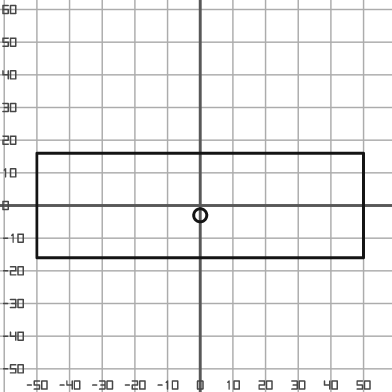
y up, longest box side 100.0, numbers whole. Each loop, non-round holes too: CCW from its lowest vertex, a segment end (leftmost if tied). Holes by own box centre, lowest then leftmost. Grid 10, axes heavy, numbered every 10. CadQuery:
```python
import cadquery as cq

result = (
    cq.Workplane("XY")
    .moveTo(-50.0, -16.0)
    .lineTo(50.0, -16.0)
    .lineTo(50.0, 16.0)
    .lineTo(-50.0, 16.0)
    .close()
    .moveTo(0.0, -3.0)
    .circle(2.0)
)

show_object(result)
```